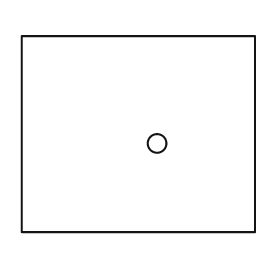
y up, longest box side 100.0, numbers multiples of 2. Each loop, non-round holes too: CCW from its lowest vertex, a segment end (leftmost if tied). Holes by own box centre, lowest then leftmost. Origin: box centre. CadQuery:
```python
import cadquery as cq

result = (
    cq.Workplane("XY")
    .moveTo(-50.0, -42.0)
    .lineTo(50.0, -42.0)
    .lineTo(50.0, 42.0)
    .lineTo(-50.0, 42.0)
    .close()
    .moveTo(8.0, -4.0)
    .circle(4.0)
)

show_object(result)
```